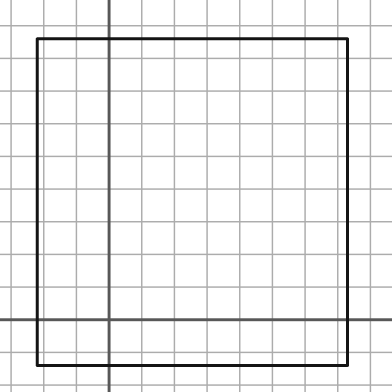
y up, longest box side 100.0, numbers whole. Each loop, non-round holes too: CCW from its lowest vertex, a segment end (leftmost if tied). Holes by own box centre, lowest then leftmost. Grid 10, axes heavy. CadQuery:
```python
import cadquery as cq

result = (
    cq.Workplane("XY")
    .moveTo(-22.0, -14.0)
    .lineTo(73.0, -14.0)
    .lineTo(73.0, 86.0)
    .lineTo(-22.0, 86.0)
    .close()
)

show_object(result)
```